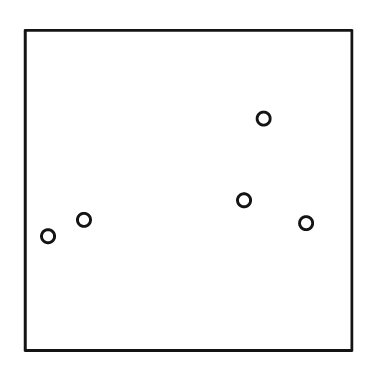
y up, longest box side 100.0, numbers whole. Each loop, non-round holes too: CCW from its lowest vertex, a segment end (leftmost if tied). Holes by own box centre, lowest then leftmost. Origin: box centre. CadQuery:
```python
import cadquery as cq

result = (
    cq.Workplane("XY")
    .moveTo(-50.0, -49.0)
    .lineTo(50.0, -49.0)
    .lineTo(50.0, 49.0)
    .lineTo(-50.0, 49.0)
    .close()
    .moveTo(-43.0, -14.0)
    .circle(2.0)
    .moveTo(36.0, -10.0)
    .circle(2.0)
    .moveTo(-32.0, -9.0)
    .circle(2.0)
    .moveTo(17.0, -3.0)
    .circle(2.0)
    .moveTo(23.0, 22.0)
    .circle(2.0)
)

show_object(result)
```